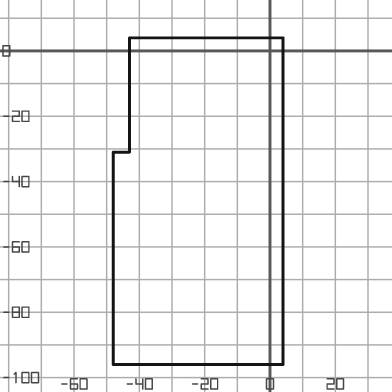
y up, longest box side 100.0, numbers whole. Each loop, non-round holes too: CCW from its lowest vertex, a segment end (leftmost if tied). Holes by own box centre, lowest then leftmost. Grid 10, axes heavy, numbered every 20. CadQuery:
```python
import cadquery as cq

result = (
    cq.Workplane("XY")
    .moveTo(-48.0, -96.0)
    .lineTo(4.0, -96.0)
    .lineTo(4.0, 4.0)
    .lineTo(-43.0, 4.0)
    .lineTo(-43.0, -31.0)
    .lineTo(-48.0, -31.0)
    .close()
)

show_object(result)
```